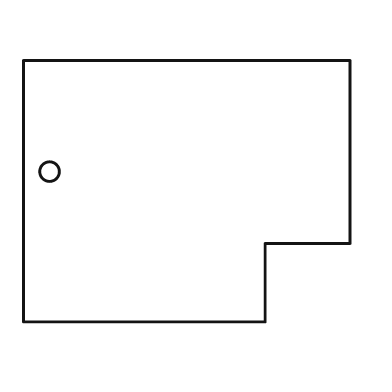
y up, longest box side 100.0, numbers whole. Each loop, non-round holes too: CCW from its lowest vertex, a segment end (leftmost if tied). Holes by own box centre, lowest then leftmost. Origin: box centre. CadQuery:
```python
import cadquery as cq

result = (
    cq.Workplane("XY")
    .moveTo(-50.0, -40.0)
    .lineTo(24.0, -40.0)
    .lineTo(24.0, -16.0)
    .lineTo(50.0, -16.0)
    .lineTo(50.0, 40.0)
    .lineTo(-50.0, 40.0)
    .close()
    .moveTo(-42.0, 6.0)
    .circle(3.0)
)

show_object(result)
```